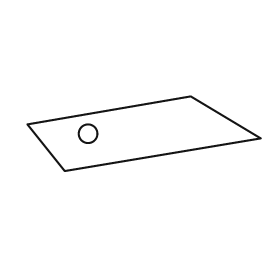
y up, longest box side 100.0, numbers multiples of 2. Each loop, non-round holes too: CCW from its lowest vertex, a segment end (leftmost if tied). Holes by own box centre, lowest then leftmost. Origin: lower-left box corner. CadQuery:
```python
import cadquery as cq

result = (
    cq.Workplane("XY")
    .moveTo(16.0, 0.0)
    .lineTo(100.0, 14.0)
    .lineTo(70.0, 32.0)
    .lineTo(0.0, 20.0)
    .close()
    .moveTo(26.0, 16.0)
    .circle(4.0)
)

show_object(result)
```